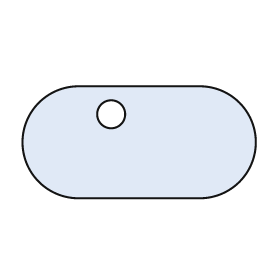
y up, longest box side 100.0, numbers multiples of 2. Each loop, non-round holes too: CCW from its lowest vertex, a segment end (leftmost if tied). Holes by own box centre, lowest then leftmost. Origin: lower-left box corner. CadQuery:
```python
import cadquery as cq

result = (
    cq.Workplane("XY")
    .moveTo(24.0, 0.0)
    .lineTo(76.0, 0.0)
    .threePointArc((100.0, 24.0), (76.0, 48.0))
    .lineTo(24.0, 48.0)
    .threePointArc((0.0, 24.0), (24.0, 0.0))
    .close()
    .moveTo(38.0, 36.0)
    .circle(6.0)
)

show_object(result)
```